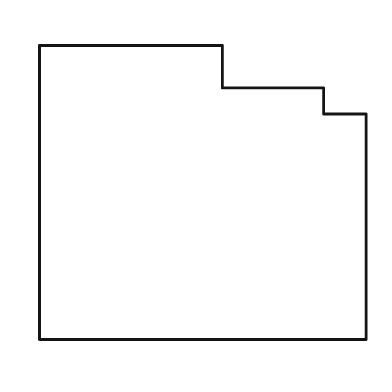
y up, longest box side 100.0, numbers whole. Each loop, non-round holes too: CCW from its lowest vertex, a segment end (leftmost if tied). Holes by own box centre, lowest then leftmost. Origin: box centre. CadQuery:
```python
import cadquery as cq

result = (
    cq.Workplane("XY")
    .moveTo(-50.0, -45.0)
    .lineTo(50.0, -45.0)
    .lineTo(50.0, 24.0)
    .lineTo(37.0, 24.0)
    .lineTo(37.0, 32.0)
    .lineTo(6.0, 32.0)
    .lineTo(6.0, 45.0)
    .lineTo(-50.0, 45.0)
    .close()
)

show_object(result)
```